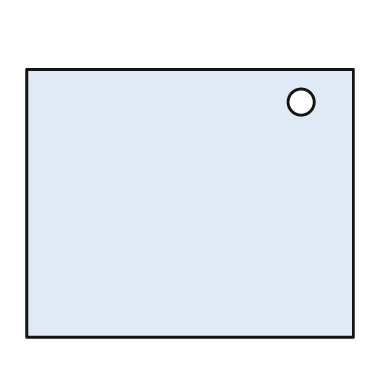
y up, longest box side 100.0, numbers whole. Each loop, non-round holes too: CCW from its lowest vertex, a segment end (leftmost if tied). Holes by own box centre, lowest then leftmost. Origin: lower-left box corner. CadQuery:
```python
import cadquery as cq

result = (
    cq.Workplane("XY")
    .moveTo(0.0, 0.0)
    .lineTo(100.0, 0.0)
    .lineTo(100.0, 82.0)
    .lineTo(0.0, 82.0)
    .close()
    .moveTo(84.0, 72.0)
    .circle(4.0)
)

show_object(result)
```